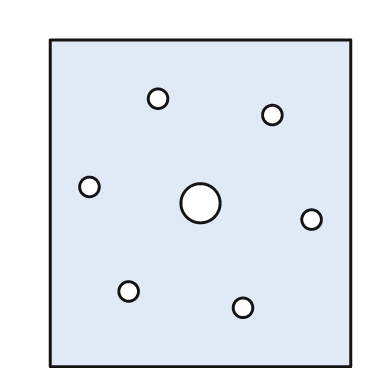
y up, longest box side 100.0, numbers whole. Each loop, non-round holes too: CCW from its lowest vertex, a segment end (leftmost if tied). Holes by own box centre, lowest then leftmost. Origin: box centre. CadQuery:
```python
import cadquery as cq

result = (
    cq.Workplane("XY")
    .moveTo(-46.0, -50.0)
    .lineTo(46.0, -50.0)
    .lineTo(46.0, 50.0)
    .lineTo(-46.0, 50.0)
    .close()
    .moveTo(13.0, -32.0)
    .circle(3.0)
    .moveTo(-22.0, -27.0)
    .circle(3.0)
    .moveTo(34.0, -5.0)
    .circle(3.0)
    .moveTo(0.0, 0.0)
    .circle(6.0)
    .moveTo(-34.0, 5.0)
    .circle(3.0)
    .moveTo(22.0, 27.0)
    .circle(3.0)
    .moveTo(-13.0, 32.0)
    .circle(3.0)
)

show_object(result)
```